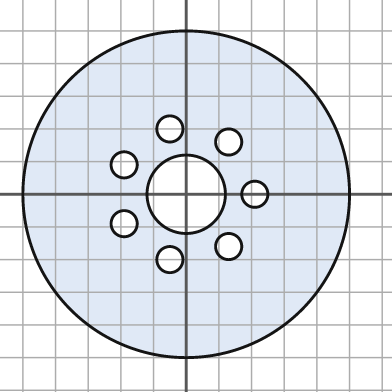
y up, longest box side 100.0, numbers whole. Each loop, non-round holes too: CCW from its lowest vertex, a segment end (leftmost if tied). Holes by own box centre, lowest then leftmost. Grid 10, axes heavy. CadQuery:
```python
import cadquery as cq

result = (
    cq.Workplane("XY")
    .moveTo(0.0, 0.0)
    .circle(50.0)
    .moveTo(-5.0, -20.0)
    .circle(4.0)
    .moveTo(13.0, -16.0)
    .circle(4.0)
    .moveTo(-19.0, -9.0)
    .circle(4.0)
    .moveTo(0.0, 0.0)
    .circle(12.0)
    .moveTo(21.0, 0.0)
    .circle(4.0)
    .moveTo(-19.0, 9.0)
    .circle(4.0)
    .moveTo(13.0, 16.0)
    .circle(4.0)
    .moveTo(-5.0, 20.0)
    .circle(4.0)
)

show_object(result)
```